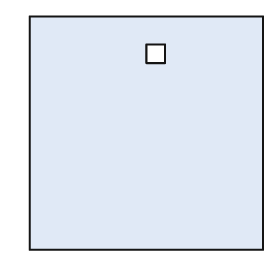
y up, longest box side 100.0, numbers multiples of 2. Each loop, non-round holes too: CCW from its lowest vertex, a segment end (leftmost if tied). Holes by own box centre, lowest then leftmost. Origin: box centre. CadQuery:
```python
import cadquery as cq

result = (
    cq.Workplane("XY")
    .moveTo(-50.0, -50.0)
    .lineTo(50.0, -50.0)
    .lineTo(50.0, 50.0)
    .lineTo(-50.0, 50.0)
    .close()
    .moveTo(0.0, 30.0)
    .lineTo(8.0, 30.0)
    .lineTo(8.0, 38.0)
    .lineTo(0.0, 38.0)
    .close()
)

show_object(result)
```